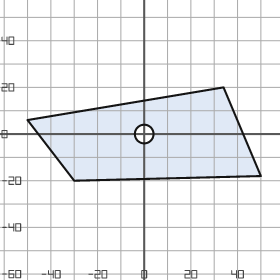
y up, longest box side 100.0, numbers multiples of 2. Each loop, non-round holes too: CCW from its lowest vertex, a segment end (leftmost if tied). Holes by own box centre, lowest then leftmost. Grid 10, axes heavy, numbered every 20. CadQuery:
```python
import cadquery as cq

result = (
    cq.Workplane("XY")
    .moveTo(-30.0, -20.0)
    .lineTo(50.0, -18.0)
    .lineTo(34.0, 20.0)
    .lineTo(-50.0, 6.0)
    .close()
    .moveTo(0.0, 0.0)
    .circle(4.0)
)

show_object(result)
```